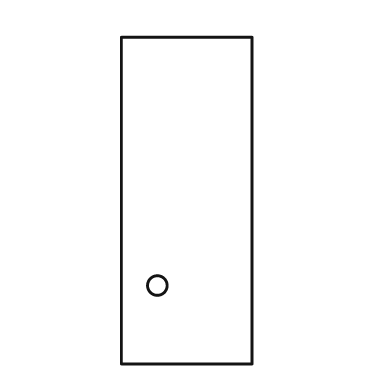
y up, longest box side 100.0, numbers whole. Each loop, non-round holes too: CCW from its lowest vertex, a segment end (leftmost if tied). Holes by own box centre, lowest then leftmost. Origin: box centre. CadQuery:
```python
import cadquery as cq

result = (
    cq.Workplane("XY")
    .moveTo(-20.0, -50.0)
    .lineTo(20.0, -50.0)
    .lineTo(20.0, 50.0)
    .lineTo(-20.0, 50.0)
    .close()
    .moveTo(-9.0, -26.0)
    .circle(3.0)
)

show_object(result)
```